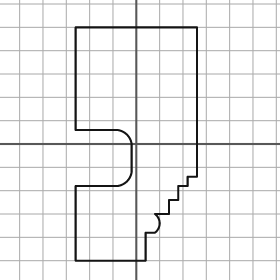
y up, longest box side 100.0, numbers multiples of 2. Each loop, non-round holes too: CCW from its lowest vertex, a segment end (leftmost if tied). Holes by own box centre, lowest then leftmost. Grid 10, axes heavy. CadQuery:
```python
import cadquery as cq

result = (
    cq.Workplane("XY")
    .moveTo(-26.0, -50.0)
    .lineTo(4.0, -50.0)
    .lineTo(4.0, -38.0)
    .lineTo(8.0, -38.0)
    .threePointArc((10.0, -34.0), (8.0, -30.0))
    .lineTo(14.0, -30.0)
    .lineTo(14.0, -24.0)
    .lineTo(18.0, -24.0)
    .lineTo(18.0, -18.0)
    .lineTo(22.0, -18.0)
    .lineTo(22.0, -14.0)
    .lineTo(26.0, -14.0)
    .lineTo(26.0, 50.0)
    .lineTo(-26.0, 50.0)
    .lineTo(-26.0, 6.0)
    .lineTo(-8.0, 6.0)
    .threePointArc((-4.0, 4.0), (-2.0, 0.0))
    .lineTo(-2.0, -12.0)
    .threePointArc((-4.0, -16.0), (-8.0, -18.0))
    .lineTo(-26.0, -18.0)
    .close()
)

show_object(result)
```